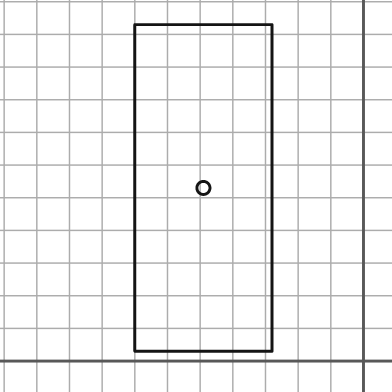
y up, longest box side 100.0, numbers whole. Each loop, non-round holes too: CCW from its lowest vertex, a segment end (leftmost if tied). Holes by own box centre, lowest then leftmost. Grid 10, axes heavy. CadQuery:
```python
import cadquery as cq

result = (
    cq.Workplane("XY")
    .moveTo(-70.0, 3.0)
    .lineTo(-28.0, 3.0)
    .lineTo(-28.0, 103.0)
    .lineTo(-70.0, 103.0)
    .close()
    .moveTo(-49.0, 53.0)
    .circle(2.0)
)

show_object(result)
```